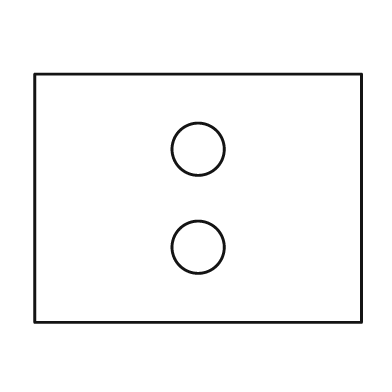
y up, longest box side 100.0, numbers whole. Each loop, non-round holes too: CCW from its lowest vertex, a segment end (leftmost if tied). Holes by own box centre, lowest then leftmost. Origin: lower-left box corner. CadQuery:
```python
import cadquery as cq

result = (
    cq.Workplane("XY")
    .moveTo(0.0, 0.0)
    .lineTo(100.0, 0.0)
    .lineTo(100.0, 76.0)
    .lineTo(0.0, 76.0)
    .close()
    .moveTo(50.0, 23.0)
    .circle(8.0)
    .moveTo(50.0, 53.0)
    .circle(8.0)
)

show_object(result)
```